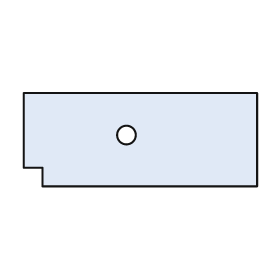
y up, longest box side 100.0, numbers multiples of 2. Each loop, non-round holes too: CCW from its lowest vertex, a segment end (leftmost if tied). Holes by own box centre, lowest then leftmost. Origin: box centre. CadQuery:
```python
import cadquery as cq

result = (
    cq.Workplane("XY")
    .moveTo(-42.0, -20.0)
    .lineTo(50.0, -20.0)
    .lineTo(50.0, 20.0)
    .lineTo(-50.0, 20.0)
    .lineTo(-50.0, -12.0)
    .lineTo(-42.0, -12.0)
    .close()
    .moveTo(-6.0, 2.0)
    .circle(4.0)
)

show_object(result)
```